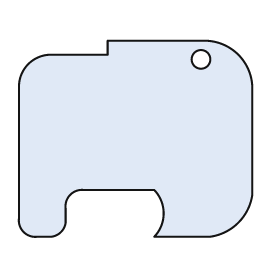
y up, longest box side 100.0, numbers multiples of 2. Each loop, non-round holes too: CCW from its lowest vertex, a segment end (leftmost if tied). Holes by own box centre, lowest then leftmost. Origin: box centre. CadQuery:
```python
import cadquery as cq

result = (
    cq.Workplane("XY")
    .moveTo(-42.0, -42.0)
    .lineTo(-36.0, -42.0)
    .threePointArc((-32.0, -40.0), (-30.0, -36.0))
    .lineTo(-30.0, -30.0)
    .threePointArc((-28.0, -24.0), (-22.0, -22.0))
    .lineTo(8.0, -22.0)
    .threePointArc((12.0, -32.0), (8.0, -42.0))
    .lineTo(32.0, -42.0)
    .threePointArc((44.0, -36.0), (50.0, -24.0))
    .lineTo(50.0, 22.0)
    .threePointArc((44.0, 36.0), (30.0, 42.0))
    .lineTo(-12.0, 42.0)
    .lineTo(-12.0, 36.0)
    .lineTo(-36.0, 36.0)
    .threePointArc((-46.0, 32.0), (-50.0, 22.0))
    .lineTo(-50.0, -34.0)
    .threePointArc((-48.0, -40.0), (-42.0, -42.0))
    .close()
    .moveTo(28.0, 34.0)
    .circle(4.0)
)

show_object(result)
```